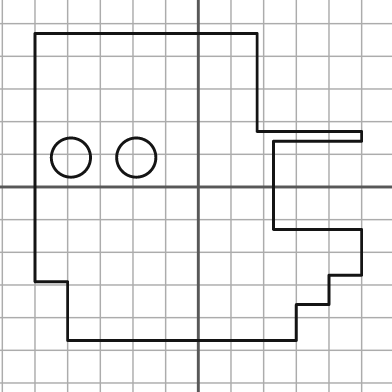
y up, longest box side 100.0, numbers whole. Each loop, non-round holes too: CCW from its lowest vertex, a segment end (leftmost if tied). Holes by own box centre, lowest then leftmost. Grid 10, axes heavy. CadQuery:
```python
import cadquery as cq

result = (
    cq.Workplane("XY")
    .moveTo(-40.0, -47.0)
    .lineTo(30.0, -47.0)
    .lineTo(30.0, -36.0)
    .lineTo(40.0, -36.0)
    .lineTo(40.0, -27.0)
    .lineTo(50.0, -27.0)
    .lineTo(50.0, -13.0)
    .lineTo(23.0, -13.0)
    .lineTo(23.0, 14.0)
    .lineTo(50.0, 14.0)
    .lineTo(50.0, 17.0)
    .lineTo(18.0, 17.0)
    .lineTo(18.0, 47.0)
    .lineTo(-50.0, 47.0)
    .lineTo(-50.0, -29.0)
    .lineTo(-40.0, -29.0)
    .close()
    .moveTo(-39.0, 9.0)
    .circle(6.0)
    .moveTo(-19.0, 9.0)
    .circle(6.0)
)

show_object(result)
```